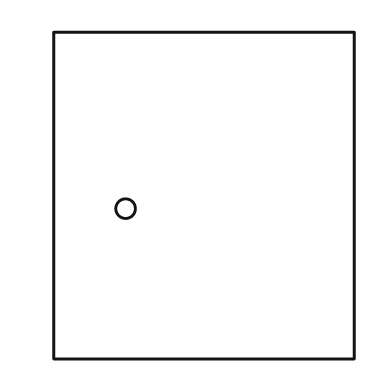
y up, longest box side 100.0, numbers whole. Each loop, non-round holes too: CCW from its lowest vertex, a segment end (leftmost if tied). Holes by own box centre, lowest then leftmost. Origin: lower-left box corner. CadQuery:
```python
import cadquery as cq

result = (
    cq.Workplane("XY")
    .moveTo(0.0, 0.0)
    .lineTo(92.0, 0.0)
    .lineTo(92.0, 100.0)
    .lineTo(0.0, 100.0)
    .close()
    .moveTo(22.0, 46.0)
    .circle(3.0)
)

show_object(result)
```